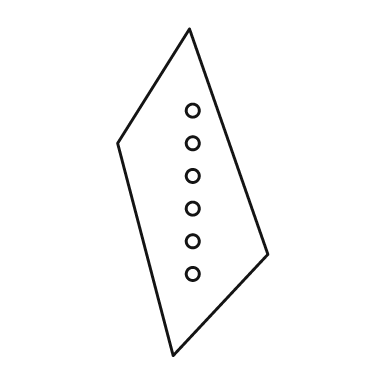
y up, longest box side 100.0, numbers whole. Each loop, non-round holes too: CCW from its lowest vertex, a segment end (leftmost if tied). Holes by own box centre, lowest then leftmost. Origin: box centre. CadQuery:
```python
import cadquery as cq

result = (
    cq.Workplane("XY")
    .moveTo(-6.0, -50.0)
    .lineTo(23.0, -19.0)
    .lineTo(-1.0, 50.0)
    .lineTo(-23.0, 15.0)
    .close()
    .moveTo(0.0, -25.0)
    .circle(2.0)
    .moveTo(0.0, -15.0)
    .circle(2.0)
    .moveTo(0.0, -5.0)
    .circle(2.0)
    .moveTo(0.0, 5.0)
    .circle(2.0)
    .moveTo(0.0, 15.0)
    .circle(2.0)
    .moveTo(0.0, 25.0)
    .circle(2.0)
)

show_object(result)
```